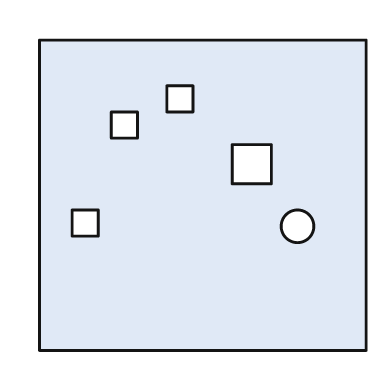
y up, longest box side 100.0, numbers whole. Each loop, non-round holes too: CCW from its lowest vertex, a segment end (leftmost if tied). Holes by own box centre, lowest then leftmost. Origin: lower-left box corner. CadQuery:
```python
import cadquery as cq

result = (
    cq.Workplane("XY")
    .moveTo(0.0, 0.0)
    .lineTo(100.0, 0.0)
    .lineTo(100.0, 95.0)
    .lineTo(0.0, 95.0)
    .close()
    .moveTo(79.0, 38.0)
    .circle(5.0)
    .moveTo(10.0, 35.0)
    .lineTo(18.0, 35.0)
    .lineTo(18.0, 43.0)
    .lineTo(10.0, 43.0)
    .close()
    .moveTo(59.0, 51.0)
    .lineTo(71.0, 51.0)
    .lineTo(71.0, 63.0)
    .lineTo(59.0, 63.0)
    .close()
    .moveTo(22.0, 65.0)
    .lineTo(30.0, 65.0)
    .lineTo(30.0, 73.0)
    .lineTo(22.0, 73.0)
    .close()
    .moveTo(39.0, 73.0)
    .lineTo(47.0, 73.0)
    .lineTo(47.0, 81.0)
    .lineTo(39.0, 81.0)
    .close()
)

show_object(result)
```